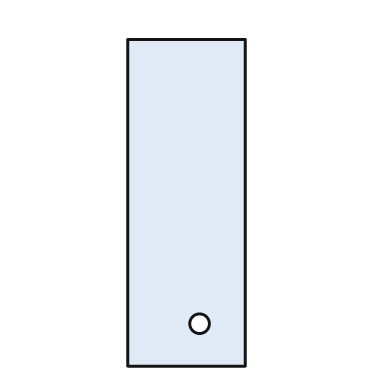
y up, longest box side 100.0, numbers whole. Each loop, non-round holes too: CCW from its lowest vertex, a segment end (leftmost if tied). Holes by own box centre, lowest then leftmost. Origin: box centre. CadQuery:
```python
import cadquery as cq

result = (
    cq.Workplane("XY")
    .moveTo(-18.0, -50.0)
    .lineTo(18.0, -50.0)
    .lineTo(18.0, 50.0)
    .lineTo(-18.0, 50.0)
    .close()
    .moveTo(4.0, -37.0)
    .circle(3.0)
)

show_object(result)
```